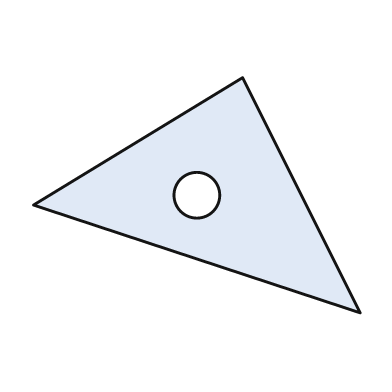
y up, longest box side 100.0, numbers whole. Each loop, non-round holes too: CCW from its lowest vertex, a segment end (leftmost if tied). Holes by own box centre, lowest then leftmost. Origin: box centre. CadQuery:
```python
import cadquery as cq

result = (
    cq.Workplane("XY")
    .moveTo(50.0, -36.0)
    .lineTo(14.0, 36.0)
    .lineTo(-50.0, -3.0)
    .close()
    .moveTo(0.0, 0.0)
    .circle(7.0)
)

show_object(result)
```